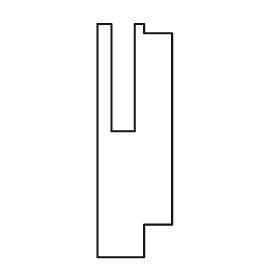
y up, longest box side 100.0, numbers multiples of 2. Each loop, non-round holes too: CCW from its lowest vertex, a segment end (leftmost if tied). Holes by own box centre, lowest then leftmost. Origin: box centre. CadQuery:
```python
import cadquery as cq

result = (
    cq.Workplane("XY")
    .moveTo(-16.0, -50.0)
    .lineTo(4.0, -50.0)
    .lineTo(4.0, -36.0)
    .lineTo(16.0, -36.0)
    .lineTo(16.0, 46.0)
    .lineTo(4.0, 46.0)
    .lineTo(4.0, 50.0)
    .lineTo(0.0, 50.0)
    .lineTo(0.0, 4.0)
    .lineTo(-10.0, 4.0)
    .lineTo(-10.0, 50.0)
    .lineTo(-16.0, 50.0)
    .close()
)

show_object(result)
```